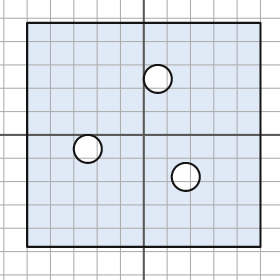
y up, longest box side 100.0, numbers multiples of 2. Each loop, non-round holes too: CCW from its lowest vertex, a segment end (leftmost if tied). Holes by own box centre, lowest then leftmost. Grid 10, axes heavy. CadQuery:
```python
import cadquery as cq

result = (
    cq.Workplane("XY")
    .moveTo(-50.0, -48.0)
    .lineTo(50.0, -48.0)
    .lineTo(50.0, 48.0)
    .lineTo(-50.0, 48.0)
    .close()
    .moveTo(18.0, -18.0)
    .circle(6.0)
    .moveTo(-24.0, -6.0)
    .circle(6.0)
    .moveTo(6.0, 24.0)
    .circle(6.0)
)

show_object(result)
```